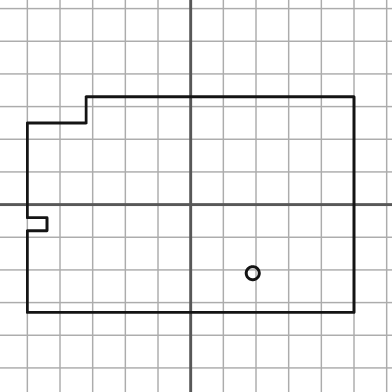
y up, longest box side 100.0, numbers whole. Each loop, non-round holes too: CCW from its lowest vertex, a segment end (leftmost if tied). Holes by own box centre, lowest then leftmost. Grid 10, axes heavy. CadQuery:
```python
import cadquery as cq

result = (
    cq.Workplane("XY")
    .moveTo(-50.0, -33.0)
    .lineTo(50.0, -33.0)
    .lineTo(50.0, 33.0)
    .lineTo(-32.0, 33.0)
    .lineTo(-32.0, 25.0)
    .lineTo(-50.0, 25.0)
    .lineTo(-50.0, -4.0)
    .lineTo(-44.0, -4.0)
    .lineTo(-44.0, -8.0)
    .lineTo(-50.0, -8.0)
    .close()
    .moveTo(19.0, -21.0)
    .circle(2.0)
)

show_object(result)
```